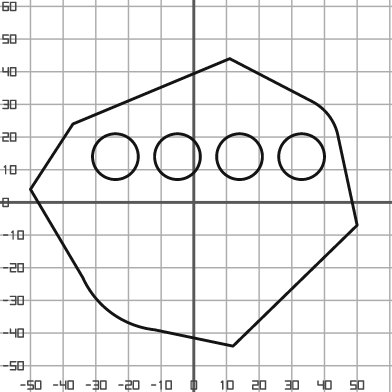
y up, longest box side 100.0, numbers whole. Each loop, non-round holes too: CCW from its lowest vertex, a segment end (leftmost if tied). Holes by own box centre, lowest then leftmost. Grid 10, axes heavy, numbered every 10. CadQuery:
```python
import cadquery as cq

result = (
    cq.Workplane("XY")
    .moveTo(12.0, -44.0)
    .lineTo(50.0, -7.0)
    .lineTo(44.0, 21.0)
    .threePointArc((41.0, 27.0), (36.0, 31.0))
    .lineTo(11.0, 44.0)
    .lineTo(-37.0, 24.0)
    .lineTo(-50.0, 4.0)
    .lineTo(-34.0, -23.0)
    .threePointArc((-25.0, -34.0), (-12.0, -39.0))
    .close()
    .moveTo(-24.0, 14.0)
    .circle(7.0)
    .moveTo(-5.0, 14.0)
    .circle(7.0)
    .moveTo(14.0, 14.0)
    .circle(7.0)
    .moveTo(33.0, 14.0)
    .circle(7.0)
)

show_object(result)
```